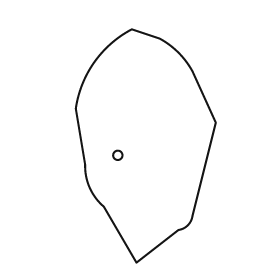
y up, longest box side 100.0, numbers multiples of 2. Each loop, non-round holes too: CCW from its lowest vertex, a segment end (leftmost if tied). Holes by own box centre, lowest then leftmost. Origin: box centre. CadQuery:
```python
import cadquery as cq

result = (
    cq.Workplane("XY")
    .moveTo(-4.0, -50.0)
    .lineTo(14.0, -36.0)
    .threePointArc((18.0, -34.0), (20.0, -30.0))
    .lineTo(30.0, 10.0)
    .lineTo(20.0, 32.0)
    .threePointArc((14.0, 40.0), (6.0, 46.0))
    .lineTo(-6.0, 50.0)
    .threePointArc((-22.0, 36.0), (-30.0, 16.0))
    .lineTo(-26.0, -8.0)
    .threePointArc((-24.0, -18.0), (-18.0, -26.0))
    .close()
    .moveTo(-12.0, -4.0)
    .circle(2.0)
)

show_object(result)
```